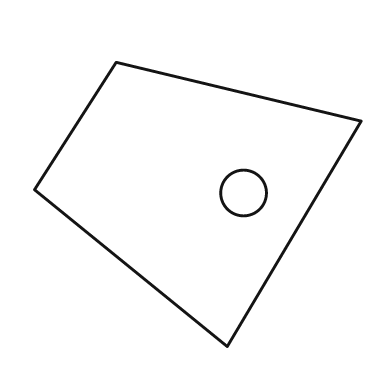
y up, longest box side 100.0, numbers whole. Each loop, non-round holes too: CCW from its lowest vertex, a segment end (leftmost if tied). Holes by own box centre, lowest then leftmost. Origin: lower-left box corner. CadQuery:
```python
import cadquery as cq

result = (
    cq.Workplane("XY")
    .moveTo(59.0, 0.0)
    .lineTo(100.0, 69.0)
    .lineTo(25.0, 87.0)
    .lineTo(0.0, 48.0)
    .close()
    .moveTo(64.0, 47.0)
    .circle(7.0)
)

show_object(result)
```